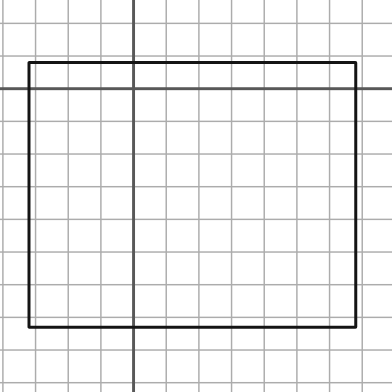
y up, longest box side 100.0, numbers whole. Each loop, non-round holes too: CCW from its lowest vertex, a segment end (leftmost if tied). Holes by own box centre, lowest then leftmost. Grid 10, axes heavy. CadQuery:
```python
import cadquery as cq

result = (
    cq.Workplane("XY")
    .moveTo(-32.0, -73.0)
    .lineTo(68.0, -73.0)
    .lineTo(68.0, 8.0)
    .lineTo(-32.0, 8.0)
    .close()
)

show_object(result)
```